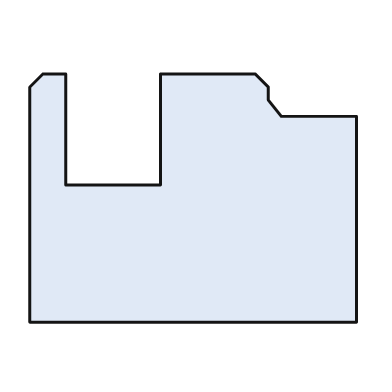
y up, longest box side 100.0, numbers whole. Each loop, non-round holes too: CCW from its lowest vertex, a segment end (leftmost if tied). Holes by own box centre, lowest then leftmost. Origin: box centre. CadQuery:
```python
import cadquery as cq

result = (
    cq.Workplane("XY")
    .moveTo(-50.0, -38.0)
    .lineTo(50.0, -38.0)
    .lineTo(50.0, 25.0)
    .lineTo(27.0, 25.0)
    .lineTo(23.0, 30.0)
    .lineTo(23.0, 34.0)
    .lineTo(19.0, 38.0)
    .lineTo(-10.0, 38.0)
    .lineTo(-10.0, 4.0)
    .lineTo(-39.0, 4.0)
    .lineTo(-39.0, 38.0)
    .lineTo(-46.0, 38.0)
    .lineTo(-50.0, 34.0)
    .close()
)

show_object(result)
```